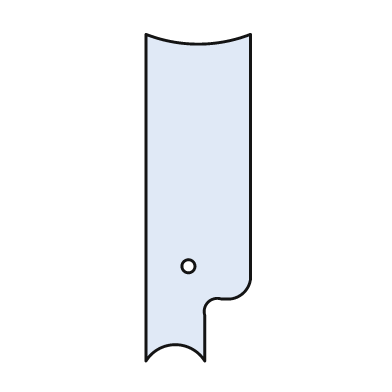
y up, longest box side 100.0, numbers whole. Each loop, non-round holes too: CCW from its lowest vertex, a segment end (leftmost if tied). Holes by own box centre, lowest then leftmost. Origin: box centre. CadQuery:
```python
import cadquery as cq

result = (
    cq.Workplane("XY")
    .moveTo(-16.0, -50.0)
    .threePointArc((-7.0, -45.0), (2.0, -50.0))
    .lineTo(2.0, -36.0)
    .threePointArc((3.0, -32.0), (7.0, -31.0))
    .lineTo(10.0, -31.0)
    .threePointArc((14.0, -29.0), (16.0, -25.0))
    .lineTo(16.0, 50.0)
    .threePointArc((0.0, 47.0), (-16.0, 50.0))
    .close()
    .moveTo(-3.0, -21.0)
    .circle(2.0)
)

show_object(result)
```